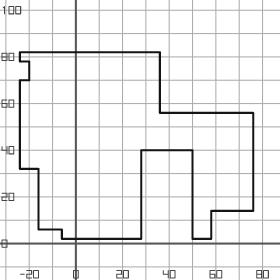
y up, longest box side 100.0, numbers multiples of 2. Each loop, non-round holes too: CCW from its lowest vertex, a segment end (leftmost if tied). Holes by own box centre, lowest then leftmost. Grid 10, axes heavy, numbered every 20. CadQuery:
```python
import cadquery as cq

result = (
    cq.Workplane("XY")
    .moveTo(-6.0, 2.0)
    .lineTo(28.0, 2.0)
    .lineTo(28.0, 40.0)
    .lineTo(50.0, 40.0)
    .lineTo(50.0, 2.0)
    .lineTo(58.0, 2.0)
    .lineTo(58.0, 14.0)
    .lineTo(76.0, 14.0)
    .lineTo(76.0, 56.0)
    .lineTo(36.0, 56.0)
    .lineTo(36.0, 82.0)
    .lineTo(-24.0, 82.0)
    .lineTo(-24.0, 78.0)
    .lineTo(-20.0, 78.0)
    .lineTo(-20.0, 70.0)
    .lineTo(-24.0, 70.0)
    .lineTo(-24.0, 32.0)
    .lineTo(-16.0, 32.0)
    .lineTo(-16.0, 6.0)
    .lineTo(-6.0, 6.0)
    .close()
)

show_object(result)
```